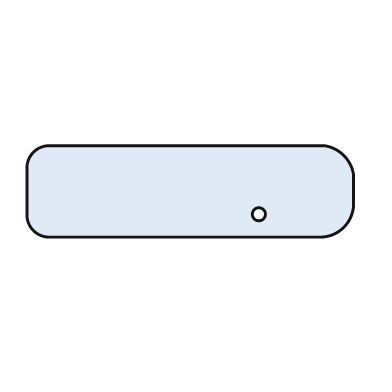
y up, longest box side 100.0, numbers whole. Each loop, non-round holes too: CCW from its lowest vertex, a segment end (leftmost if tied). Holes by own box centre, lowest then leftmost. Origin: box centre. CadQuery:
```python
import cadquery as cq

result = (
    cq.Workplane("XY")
    .moveTo(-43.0, -14.0)
    .lineTo(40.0, -14.0)
    .threePointArc((47.0, -11.0), (50.0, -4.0))
    .lineTo(50.0, 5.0)
    .threePointArc((47.0, 11.0), (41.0, 14.0))
    .lineTo(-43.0, 14.0)
    .threePointArc((-48.0, 12.0), (-50.0, 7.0))
    .lineTo(-50.0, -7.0)
    .threePointArc((-48.0, -12.0), (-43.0, -14.0))
    .close()
    .moveTo(21.0, -7.0)
    .circle(2.0)
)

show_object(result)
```